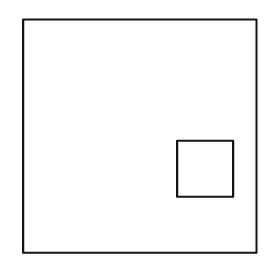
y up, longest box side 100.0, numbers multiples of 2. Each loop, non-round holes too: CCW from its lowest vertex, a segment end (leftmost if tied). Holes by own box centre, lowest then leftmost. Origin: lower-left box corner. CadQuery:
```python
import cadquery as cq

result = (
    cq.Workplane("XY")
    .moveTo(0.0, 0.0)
    .lineTo(100.0, 0.0)
    .lineTo(100.0, 100.0)
    .lineTo(0.0, 100.0)
    .close()
    .moveTo(66.0, 24.0)
    .lineTo(90.0, 24.0)
    .lineTo(90.0, 48.0)
    .lineTo(66.0, 48.0)
    .close()
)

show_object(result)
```